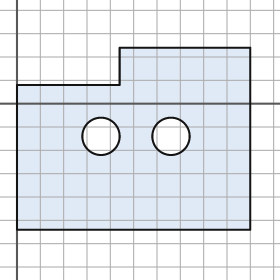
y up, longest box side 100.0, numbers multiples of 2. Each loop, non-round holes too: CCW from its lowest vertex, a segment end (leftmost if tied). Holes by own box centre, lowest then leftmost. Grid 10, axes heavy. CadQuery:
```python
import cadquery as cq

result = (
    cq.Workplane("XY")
    .moveTo(0.0, -54.0)
    .lineTo(100.0, -54.0)
    .lineTo(100.0, 24.0)
    .lineTo(44.0, 24.0)
    .lineTo(44.0, 8.0)
    .lineTo(0.0, 8.0)
    .close()
    .moveTo(36.0, -14.0)
    .circle(8.0)
    .moveTo(66.0, -14.0)
    .circle(8.0)
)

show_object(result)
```